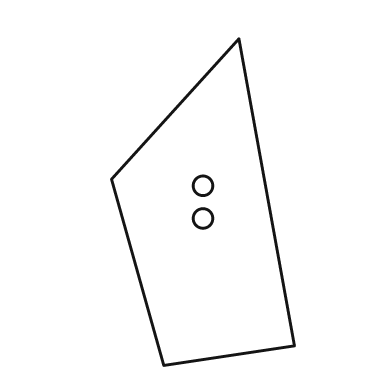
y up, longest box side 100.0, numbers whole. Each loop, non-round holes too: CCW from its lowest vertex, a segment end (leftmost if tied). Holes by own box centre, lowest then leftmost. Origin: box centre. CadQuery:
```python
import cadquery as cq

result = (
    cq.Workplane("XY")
    .moveTo(-12.0, -50.0)
    .lineTo(28.0, -44.0)
    .lineTo(11.0, 50.0)
    .lineTo(-28.0, 7.0)
    .close()
    .moveTo(0.0, -5.0)
    .circle(3.0)
    .moveTo(0.0, 5.0)
    .circle(3.0)
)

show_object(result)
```